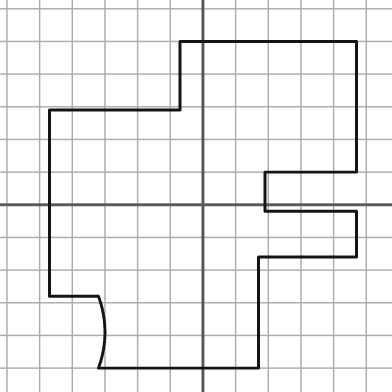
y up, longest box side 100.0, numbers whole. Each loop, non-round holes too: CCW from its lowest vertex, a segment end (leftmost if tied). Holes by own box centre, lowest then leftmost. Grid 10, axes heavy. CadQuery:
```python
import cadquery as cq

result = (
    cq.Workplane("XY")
    .moveTo(-32.0, -50.0)
    .lineTo(17.0, -50.0)
    .lineTo(17.0, -16.0)
    .lineTo(47.0, -16.0)
    .lineTo(47.0, -2.0)
    .lineTo(19.0, -2.0)
    .lineTo(19.0, 10.0)
    .lineTo(47.0, 10.0)
    .lineTo(47.0, 50.0)
    .lineTo(-7.0, 50.0)
    .lineTo(-7.0, 29.0)
    .lineTo(-47.0, 29.0)
    .lineTo(-47.0, -28.0)
    .lineTo(-32.0, -28.0)
    .threePointArc((-30.0, -39.0), (-32.0, -50.0))
    .close()
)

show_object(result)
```